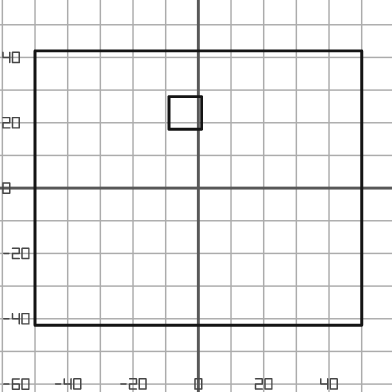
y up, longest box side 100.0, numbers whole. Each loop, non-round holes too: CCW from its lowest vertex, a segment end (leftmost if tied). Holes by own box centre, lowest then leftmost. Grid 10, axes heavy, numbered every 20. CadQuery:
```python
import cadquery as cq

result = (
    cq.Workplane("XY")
    .moveTo(-50.0, -42.0)
    .lineTo(50.0, -42.0)
    .lineTo(50.0, 42.0)
    .lineTo(-50.0, 42.0)
    .close()
    .moveTo(-9.0, 18.0)
    .lineTo(1.0, 18.0)
    .lineTo(1.0, 28.0)
    .lineTo(-9.0, 28.0)
    .close()
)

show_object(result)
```